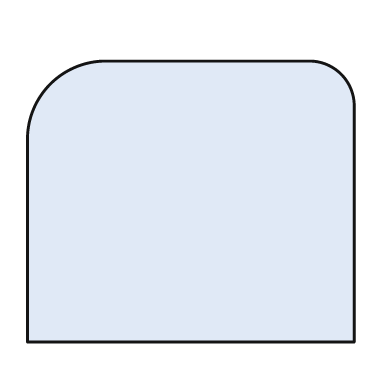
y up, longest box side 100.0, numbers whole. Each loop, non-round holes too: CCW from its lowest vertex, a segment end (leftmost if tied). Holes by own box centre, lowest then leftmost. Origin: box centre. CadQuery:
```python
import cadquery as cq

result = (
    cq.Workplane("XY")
    .moveTo(-50.0, -43.0)
    .lineTo(50.0, -43.0)
    .lineTo(50.0, 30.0)
    .threePointArc((46.0, 39.0), (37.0, 43.0))
    .lineTo(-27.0, 43.0)
    .threePointArc((-43.0, 36.0), (-50.0, 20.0))
    .close()
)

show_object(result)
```